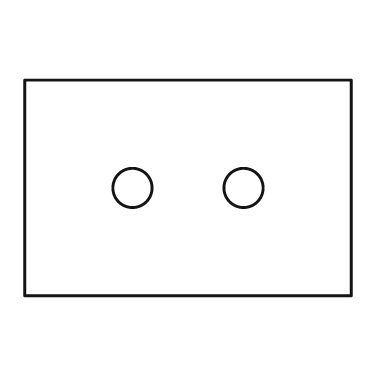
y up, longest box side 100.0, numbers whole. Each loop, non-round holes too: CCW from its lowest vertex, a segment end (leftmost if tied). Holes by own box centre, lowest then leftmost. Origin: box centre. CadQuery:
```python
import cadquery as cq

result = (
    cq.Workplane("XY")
    .moveTo(-50.0, -33.0)
    .lineTo(50.0, -33.0)
    .lineTo(50.0, 33.0)
    .lineTo(-50.0, 33.0)
    .close()
    .moveTo(-17.0, 0.0)
    .circle(6.0)
    .moveTo(17.0, 0.0)
    .circle(6.0)
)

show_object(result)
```